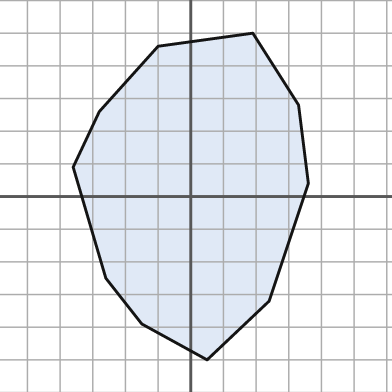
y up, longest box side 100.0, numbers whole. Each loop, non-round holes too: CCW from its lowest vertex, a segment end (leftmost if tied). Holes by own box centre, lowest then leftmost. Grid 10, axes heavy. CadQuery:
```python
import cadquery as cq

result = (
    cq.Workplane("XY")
    .moveTo(5.0, -50.0)
    .lineTo(24.0, -32.0)
    .lineTo(36.0, 4.0)
    .lineTo(33.0, 28.0)
    .lineTo(19.0, 50.0)
    .lineTo(-10.0, 46.0)
    .lineTo(-28.0, 26.0)
    .lineTo(-36.0, 9.0)
    .lineTo(-26.0, -25.0)
    .lineTo(-15.0, -39.0)
    .close()
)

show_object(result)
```